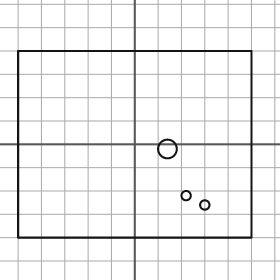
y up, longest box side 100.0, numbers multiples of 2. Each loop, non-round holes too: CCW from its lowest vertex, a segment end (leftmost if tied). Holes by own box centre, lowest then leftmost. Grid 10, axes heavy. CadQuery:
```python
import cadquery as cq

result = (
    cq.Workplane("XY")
    .moveTo(-50.0, -40.0)
    .lineTo(50.0, -40.0)
    .lineTo(50.0, 40.0)
    .lineTo(-50.0, 40.0)
    .close()
    .moveTo(30.0, -26.0)
    .circle(2.0)
    .moveTo(22.0, -22.0)
    .circle(2.0)
    .moveTo(14.0, -2.0)
    .circle(4.0)
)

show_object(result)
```